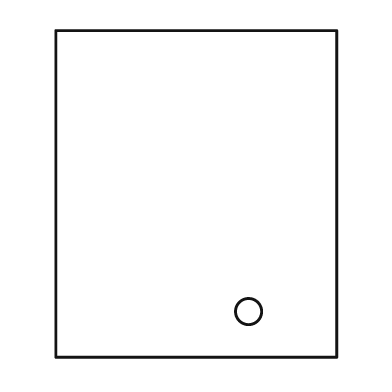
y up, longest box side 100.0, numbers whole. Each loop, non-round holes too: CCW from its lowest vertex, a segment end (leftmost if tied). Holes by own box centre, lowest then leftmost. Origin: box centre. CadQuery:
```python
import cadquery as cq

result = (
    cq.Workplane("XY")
    .moveTo(-43.0, -50.0)
    .lineTo(43.0, -50.0)
    .lineTo(43.0, 50.0)
    .lineTo(-43.0, 50.0)
    .close()
    .moveTo(16.0, -36.0)
    .circle(4.0)
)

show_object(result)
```